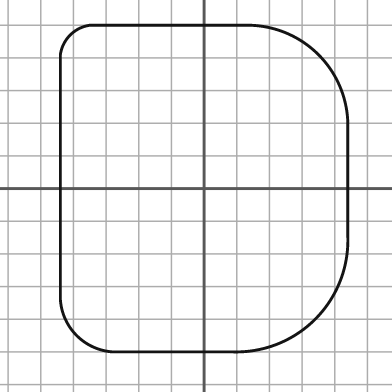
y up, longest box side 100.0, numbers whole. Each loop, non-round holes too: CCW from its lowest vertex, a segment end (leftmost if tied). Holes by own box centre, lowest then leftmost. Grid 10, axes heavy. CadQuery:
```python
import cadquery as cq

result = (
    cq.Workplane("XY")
    .moveTo(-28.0, -50.0)
    .lineTo(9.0, -50.0)
    .threePointArc((34.0, -40.0), (44.0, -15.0))
    .lineTo(44.0, 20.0)
    .threePointArc((35.0, 41.0), (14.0, 50.0))
    .lineTo(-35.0, 50.0)
    .threePointArc((-41.0, 47.0), (-44.0, 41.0))
    .lineTo(-44.0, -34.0)
    .threePointArc((-39.0, -45.0), (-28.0, -50.0))
    .close()
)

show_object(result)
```